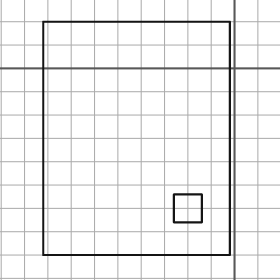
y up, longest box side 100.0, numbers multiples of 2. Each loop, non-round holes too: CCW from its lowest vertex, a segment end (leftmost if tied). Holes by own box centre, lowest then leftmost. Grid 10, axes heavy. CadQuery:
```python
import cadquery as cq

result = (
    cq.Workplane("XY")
    .moveTo(-82.0, -80.0)
    .lineTo(-2.0, -80.0)
    .lineTo(-2.0, 20.0)
    .lineTo(-82.0, 20.0)
    .close()
    .moveTo(-26.0, -66.0)
    .lineTo(-14.0, -66.0)
    .lineTo(-14.0, -54.0)
    .lineTo(-26.0, -54.0)
    .close()
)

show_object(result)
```